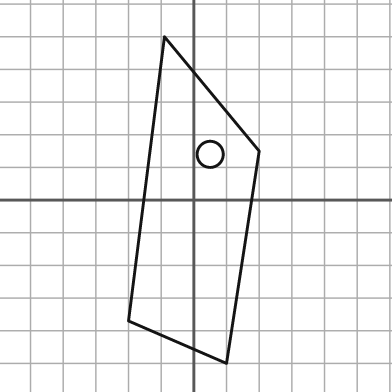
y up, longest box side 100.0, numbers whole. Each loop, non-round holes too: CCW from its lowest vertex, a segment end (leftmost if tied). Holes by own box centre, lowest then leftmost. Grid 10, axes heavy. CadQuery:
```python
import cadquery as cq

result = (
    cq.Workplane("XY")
    .moveTo(10.0, -50.0)
    .lineTo(20.0, 15.0)
    .lineTo(-9.0, 50.0)
    .lineTo(-20.0, -37.0)
    .close()
    .moveTo(5.0, 14.0)
    .circle(4.0)
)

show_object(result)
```